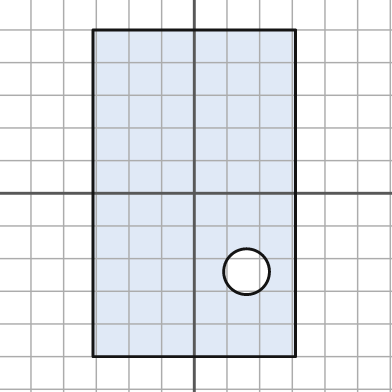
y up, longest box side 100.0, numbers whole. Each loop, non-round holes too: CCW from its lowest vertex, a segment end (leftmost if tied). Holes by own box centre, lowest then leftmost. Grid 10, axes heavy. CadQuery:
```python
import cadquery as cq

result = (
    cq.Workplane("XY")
    .moveTo(-31.0, -50.0)
    .lineTo(31.0, -50.0)
    .lineTo(31.0, 50.0)
    .lineTo(-31.0, 50.0)
    .close()
    .moveTo(16.0, -24.0)
    .circle(7.0)
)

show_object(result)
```